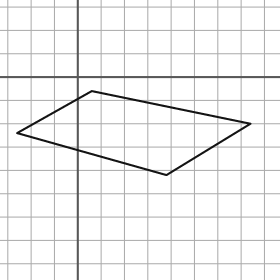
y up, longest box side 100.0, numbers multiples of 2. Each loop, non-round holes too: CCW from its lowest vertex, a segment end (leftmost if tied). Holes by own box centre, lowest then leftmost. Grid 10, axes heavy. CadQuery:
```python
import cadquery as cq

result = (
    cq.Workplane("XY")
    .moveTo(38.0, -42.0)
    .lineTo(74.0, -20.0)
    .lineTo(6.0, -6.0)
    .lineTo(-26.0, -24.0)
    .close()
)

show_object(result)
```